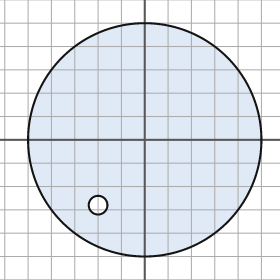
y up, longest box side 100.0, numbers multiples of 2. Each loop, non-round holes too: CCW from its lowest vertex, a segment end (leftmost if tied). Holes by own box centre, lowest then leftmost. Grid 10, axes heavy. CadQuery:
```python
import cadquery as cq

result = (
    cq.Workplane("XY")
    .moveTo(0.0, 0.0)
    .circle(50.0)
    .moveTo(-20.0, -28.0)
    .circle(4.0)
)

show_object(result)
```